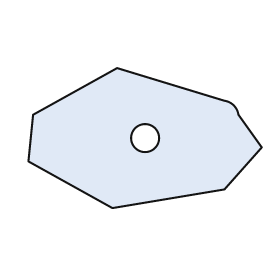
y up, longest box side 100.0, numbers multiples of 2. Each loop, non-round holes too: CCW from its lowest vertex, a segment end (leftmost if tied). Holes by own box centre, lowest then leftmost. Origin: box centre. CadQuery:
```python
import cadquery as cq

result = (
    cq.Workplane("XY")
    .moveTo(-14.0, -30.0)
    .lineTo(34.0, -22.0)
    .lineTo(50.0, -4.0)
    .lineTo(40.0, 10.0)
    .threePointArc((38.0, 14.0), (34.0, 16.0))
    .lineTo(-12.0, 30.0)
    .lineTo(-48.0, 10.0)
    .lineTo(-50.0, -10.0)
    .close()
    .moveTo(0.0, 0.0)
    .circle(6.0)
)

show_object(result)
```